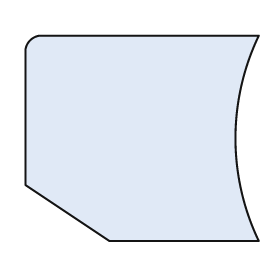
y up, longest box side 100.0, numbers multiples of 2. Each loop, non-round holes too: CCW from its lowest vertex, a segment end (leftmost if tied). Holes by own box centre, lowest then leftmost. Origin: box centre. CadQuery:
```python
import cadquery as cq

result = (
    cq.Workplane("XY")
    .moveTo(-14.0, -44.0)
    .lineTo(50.0, -44.0)
    .threePointArc((40.0, 0.0), (50.0, 44.0))
    .lineTo(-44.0, 44.0)
    .threePointArc((-48.0, 42.0), (-50.0, 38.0))
    .lineTo(-50.0, -20.0)
    .close()
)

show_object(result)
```